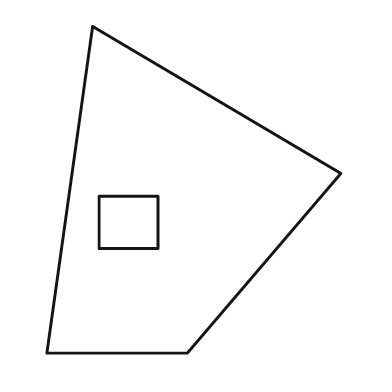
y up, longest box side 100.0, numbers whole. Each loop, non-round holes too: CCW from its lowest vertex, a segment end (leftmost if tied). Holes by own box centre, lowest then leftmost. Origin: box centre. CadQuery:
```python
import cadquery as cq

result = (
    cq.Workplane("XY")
    .moveTo(-45.0, -50.0)
    .lineTo(-2.0, -50.0)
    .lineTo(45.0, 5.0)
    .lineTo(-31.0, 50.0)
    .close()
    .moveTo(-29.0, -18.0)
    .lineTo(-11.0, -18.0)
    .lineTo(-11.0, -2.0)
    .lineTo(-29.0, -2.0)
    .close()
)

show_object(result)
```